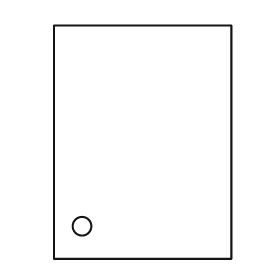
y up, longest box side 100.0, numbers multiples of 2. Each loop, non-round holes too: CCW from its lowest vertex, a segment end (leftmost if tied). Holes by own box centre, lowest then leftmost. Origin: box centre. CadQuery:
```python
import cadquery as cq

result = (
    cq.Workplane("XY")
    .moveTo(-38.0, -50.0)
    .lineTo(38.0, -50.0)
    .lineTo(38.0, 50.0)
    .lineTo(-38.0, 50.0)
    .close()
    .moveTo(-26.0, -36.0)
    .circle(4.0)
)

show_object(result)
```